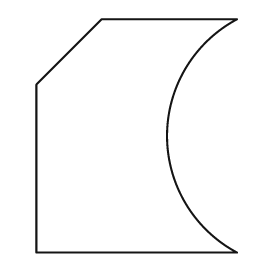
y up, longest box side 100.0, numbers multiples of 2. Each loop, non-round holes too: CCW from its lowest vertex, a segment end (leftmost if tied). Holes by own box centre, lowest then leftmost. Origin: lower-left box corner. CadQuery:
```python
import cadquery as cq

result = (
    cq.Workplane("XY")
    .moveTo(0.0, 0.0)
    .lineTo(86.0, 0.0)
    .threePointArc((56.0, 50.0), (86.0, 100.0))
    .lineTo(28.0, 100.0)
    .lineTo(0.0, 72.0)
    .close()
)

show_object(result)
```